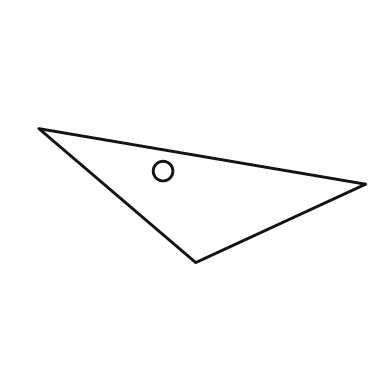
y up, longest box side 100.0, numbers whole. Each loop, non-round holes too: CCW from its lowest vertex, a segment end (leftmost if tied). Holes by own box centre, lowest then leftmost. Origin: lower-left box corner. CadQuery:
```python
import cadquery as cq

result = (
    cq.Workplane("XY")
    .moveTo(48.0, 0.0)
    .lineTo(100.0, 24.0)
    .lineTo(0.0, 41.0)
    .close()
    .moveTo(38.0, 28.0)
    .circle(3.0)
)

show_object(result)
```